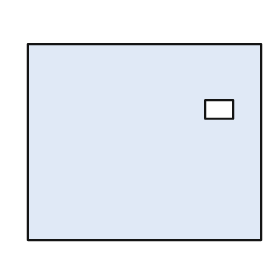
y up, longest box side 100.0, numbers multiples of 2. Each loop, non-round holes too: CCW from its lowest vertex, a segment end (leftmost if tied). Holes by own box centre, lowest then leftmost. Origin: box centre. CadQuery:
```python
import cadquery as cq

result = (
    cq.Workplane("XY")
    .moveTo(-50.0, -42.0)
    .lineTo(50.0, -42.0)
    .lineTo(50.0, 42.0)
    .lineTo(-50.0, 42.0)
    .close()
    .moveTo(26.0, 10.0)
    .lineTo(38.0, 10.0)
    .lineTo(38.0, 18.0)
    .lineTo(26.0, 18.0)
    .close()
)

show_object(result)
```